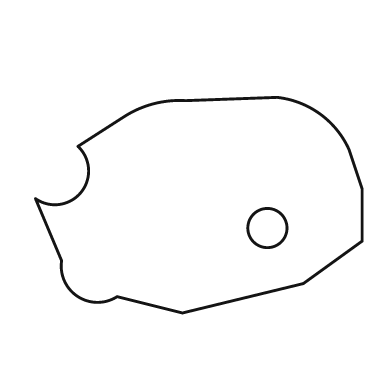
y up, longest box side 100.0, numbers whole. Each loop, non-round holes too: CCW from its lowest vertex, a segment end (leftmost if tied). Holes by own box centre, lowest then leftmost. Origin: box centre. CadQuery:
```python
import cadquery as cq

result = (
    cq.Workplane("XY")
    .moveTo(-5.0, -33.0)
    .lineTo(32.0, -24.0)
    .lineTo(50.0, -11.0)
    .lineTo(50.0, 5.0)
    .lineTo(46.0, 17.0)
    .threePointArc((37.0, 28.0), (24.0, 33.0))
    .lineTo(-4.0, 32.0)
    .threePointArc((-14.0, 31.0), (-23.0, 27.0))
    .lineTo(-37.0, 18.0)
    .threePointArc((-36.0, 4.0), (-50.0, 2.0))
    .lineTo(-42.0, -17.0)
    .threePointArc((-37.0, -28.0), (-25.0, -28.0))
    .close()
    .moveTo(21.0, -7.0)
    .circle(6.0)
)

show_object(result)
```